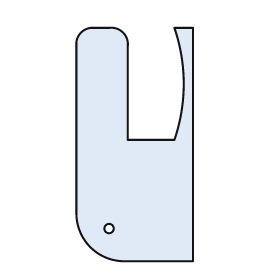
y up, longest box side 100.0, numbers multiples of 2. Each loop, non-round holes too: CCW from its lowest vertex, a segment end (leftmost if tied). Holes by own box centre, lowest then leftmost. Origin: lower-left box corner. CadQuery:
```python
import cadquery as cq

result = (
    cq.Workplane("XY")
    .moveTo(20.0, 0.0)
    .lineTo(50.0, 0.0)
    .lineTo(50.0, 100.0)
    .lineTo(42.0, 100.0)
    .threePointArc((46.0, 76.0), (42.0, 52.0))
    .lineTo(22.0, 52.0)
    .lineTo(22.0, 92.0)
    .threePointArc((20.0, 98.0), (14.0, 100.0))
    .lineTo(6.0, 100.0)
    .threePointArc((2.0, 98.0), (0.0, 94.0))
    .lineTo(0.0, 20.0)
    .threePointArc((6.0, 6.0), (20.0, 0.0))
    .close()
    .moveTo(14.0, 14.0)
    .circle(2.0)
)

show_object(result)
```